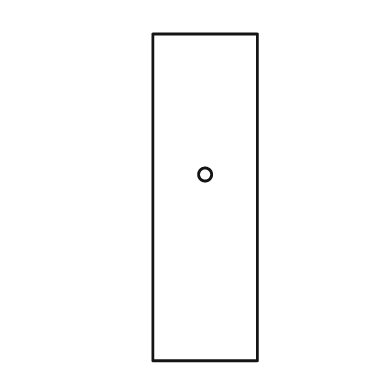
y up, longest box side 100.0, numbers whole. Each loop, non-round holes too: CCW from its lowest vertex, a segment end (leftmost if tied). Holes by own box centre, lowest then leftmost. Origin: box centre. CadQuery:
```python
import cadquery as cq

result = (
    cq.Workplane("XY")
    .moveTo(-16.0, -50.0)
    .lineTo(16.0, -50.0)
    .lineTo(16.0, 50.0)
    .lineTo(-16.0, 50.0)
    .close()
    .moveTo(0.0, 7.0)
    .circle(2.0)
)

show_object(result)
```